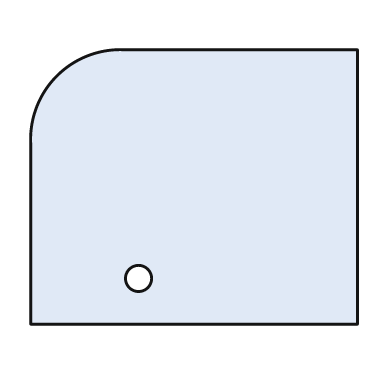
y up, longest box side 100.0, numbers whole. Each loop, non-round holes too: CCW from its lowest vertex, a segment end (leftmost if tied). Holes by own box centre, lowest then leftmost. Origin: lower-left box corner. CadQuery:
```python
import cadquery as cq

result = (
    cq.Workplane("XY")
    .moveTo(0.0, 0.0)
    .lineTo(100.0, 0.0)
    .lineTo(100.0, 84.0)
    .lineTo(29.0, 84.0)
    .threePointArc((8.0, 76.0), (0.0, 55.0))
    .close()
    .moveTo(33.0, 14.0)
    .circle(4.0)
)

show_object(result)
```